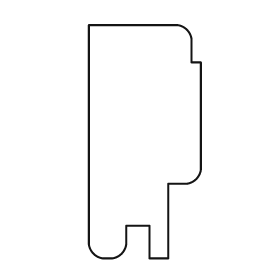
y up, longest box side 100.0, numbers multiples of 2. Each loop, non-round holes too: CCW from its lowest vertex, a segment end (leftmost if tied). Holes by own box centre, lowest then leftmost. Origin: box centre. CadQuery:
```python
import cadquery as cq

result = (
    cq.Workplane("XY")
    .moveTo(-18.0, -50.0)
    .lineTo(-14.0, -50.0)
    .threePointArc((-10.0, -48.0), (-8.0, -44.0))
    .lineTo(-8.0, -36.0)
    .lineTo(2.0, -36.0)
    .lineTo(2.0, -50.0)
    .lineTo(10.0, -50.0)
    .lineTo(10.0, -18.0)
    .lineTo(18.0, -18.0)
    .threePointArc((22.0, -16.0), (24.0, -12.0))
    .lineTo(24.0, 34.0)
    .lineTo(20.0, 34.0)
    .lineTo(20.0, 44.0)
    .threePointArc((18.0, 48.0), (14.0, 50.0))
    .lineTo(-24.0, 50.0)
    .lineTo(-24.0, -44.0)
    .threePointArc((-22.0, -48.0), (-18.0, -50.0))
    .close()
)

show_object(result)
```